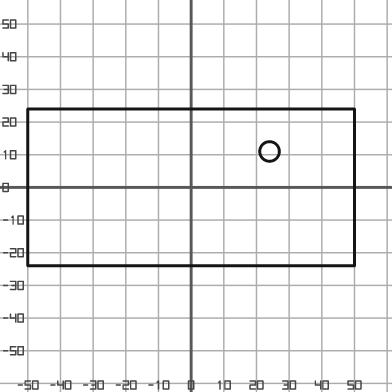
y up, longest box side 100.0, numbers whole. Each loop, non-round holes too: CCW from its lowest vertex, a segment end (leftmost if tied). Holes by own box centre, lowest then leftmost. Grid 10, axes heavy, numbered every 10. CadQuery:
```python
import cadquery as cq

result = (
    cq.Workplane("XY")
    .moveTo(-50.0, -24.0)
    .lineTo(50.0, -24.0)
    .lineTo(50.0, 24.0)
    .lineTo(-50.0, 24.0)
    .close()
    .moveTo(24.0, 11.0)
    .circle(3.0)
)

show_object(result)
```